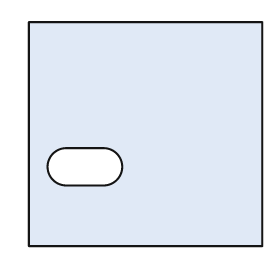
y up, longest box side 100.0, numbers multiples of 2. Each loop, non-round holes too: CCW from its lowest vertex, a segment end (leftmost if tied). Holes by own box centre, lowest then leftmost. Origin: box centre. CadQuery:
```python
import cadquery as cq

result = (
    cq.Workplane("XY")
    .moveTo(-50.0, -48.0)
    .lineTo(50.0, -48.0)
    .lineTo(50.0, 48.0)
    .lineTo(-50.0, 48.0)
    .close()
    .moveTo(-34.0, -22.0)
    .lineTo(-18.0, -22.0)
    .threePointArc((-10.0, -14.0), (-18.0, -6.0))
    .lineTo(-34.0, -6.0)
    .threePointArc((-42.0, -14.0), (-34.0, -22.0))
    .close()
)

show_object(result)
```